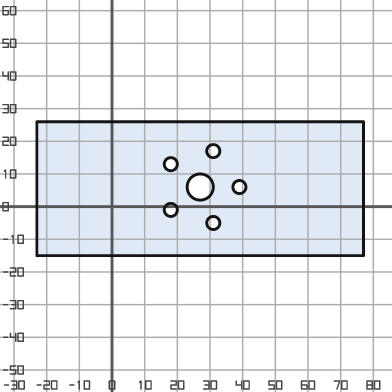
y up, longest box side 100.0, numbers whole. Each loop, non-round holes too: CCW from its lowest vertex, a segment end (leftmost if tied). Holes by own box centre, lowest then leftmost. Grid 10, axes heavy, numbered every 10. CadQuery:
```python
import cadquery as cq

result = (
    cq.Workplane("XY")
    .moveTo(-23.0, -15.0)
    .lineTo(77.0, -15.0)
    .lineTo(77.0, 26.0)
    .lineTo(-23.0, 26.0)
    .close()
    .moveTo(31.0, -5.0)
    .circle(2.0)
    .moveTo(18.0, -1.0)
    .circle(2.0)
    .moveTo(27.0, 6.0)
    .circle(4.0)
    .moveTo(39.0, 6.0)
    .circle(2.0)
    .moveTo(18.0, 13.0)
    .circle(2.0)
    .moveTo(31.0, 17.0)
    .circle(2.0)
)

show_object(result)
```